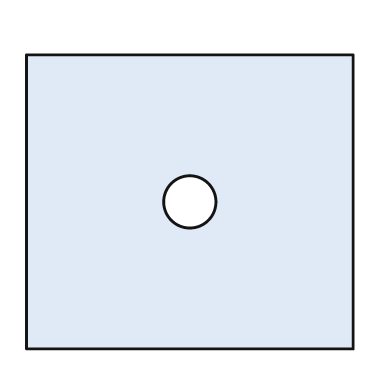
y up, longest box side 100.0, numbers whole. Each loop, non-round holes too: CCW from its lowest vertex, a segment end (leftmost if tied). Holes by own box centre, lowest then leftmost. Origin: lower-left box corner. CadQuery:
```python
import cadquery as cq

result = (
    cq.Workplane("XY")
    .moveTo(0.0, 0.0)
    .lineTo(100.0, 0.0)
    .lineTo(100.0, 90.0)
    .lineTo(0.0, 90.0)
    .close()
    .moveTo(50.0, 45.0)
    .circle(8.0)
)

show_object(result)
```